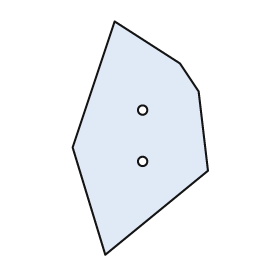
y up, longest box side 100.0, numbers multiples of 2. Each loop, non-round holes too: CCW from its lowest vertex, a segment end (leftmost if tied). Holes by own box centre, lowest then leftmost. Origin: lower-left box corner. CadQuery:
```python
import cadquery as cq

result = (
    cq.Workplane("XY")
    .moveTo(14.0, 0.0)
    .lineTo(58.0, 36.0)
    .lineTo(54.0, 70.0)
    .lineTo(46.0, 82.0)
    .lineTo(18.0, 100.0)
    .lineTo(0.0, 46.0)
    .close()
    .moveTo(30.0, 40.0)
    .circle(2.0)
    .moveTo(30.0, 62.0)
    .circle(2.0)
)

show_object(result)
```